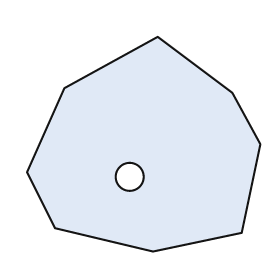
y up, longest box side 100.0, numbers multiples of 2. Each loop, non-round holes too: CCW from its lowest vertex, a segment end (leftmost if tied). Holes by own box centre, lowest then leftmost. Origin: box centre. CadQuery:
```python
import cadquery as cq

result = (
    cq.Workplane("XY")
    .moveTo(4.0, -46.0)
    .lineTo(42.0, -38.0)
    .lineTo(50.0, 0.0)
    .lineTo(38.0, 22.0)
    .lineTo(6.0, 46.0)
    .lineTo(-34.0, 24.0)
    .lineTo(-50.0, -12.0)
    .lineTo(-38.0, -36.0)
    .close()
    .moveTo(-6.0, -14.0)
    .circle(6.0)
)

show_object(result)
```